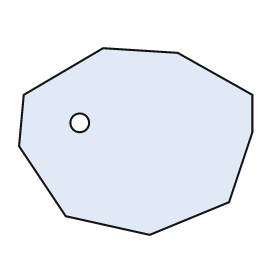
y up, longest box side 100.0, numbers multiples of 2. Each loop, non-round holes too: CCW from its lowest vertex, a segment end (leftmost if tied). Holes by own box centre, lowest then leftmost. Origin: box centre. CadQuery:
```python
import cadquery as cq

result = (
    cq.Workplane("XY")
    .moveTo(6.0, -40.0)
    .lineTo(40.0, -26.0)
    .lineTo(50.0, 4.0)
    .lineTo(50.0, 20.0)
    .lineTo(18.0, 38.0)
    .lineTo(-14.0, 40.0)
    .lineTo(-48.0, 20.0)
    .lineTo(-50.0, -2.0)
    .lineTo(-30.0, -32.0)
    .close()
    .moveTo(-24.0, 8.0)
    .circle(4.0)
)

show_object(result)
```